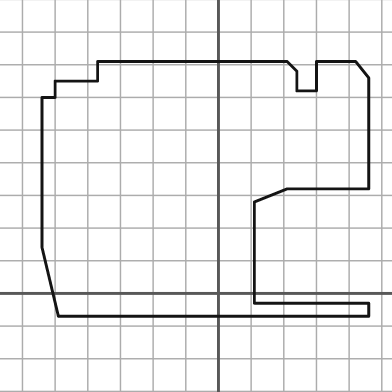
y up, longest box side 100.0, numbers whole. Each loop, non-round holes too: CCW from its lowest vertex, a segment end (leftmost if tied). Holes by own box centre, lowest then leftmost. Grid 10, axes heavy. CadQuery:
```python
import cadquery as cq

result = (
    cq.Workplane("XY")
    .moveTo(-49.0, -7.0)
    .lineTo(46.0, -7.0)
    .lineTo(46.0, -3.0)
    .lineTo(11.0, -3.0)
    .lineTo(11.0, 28.0)
    .lineTo(21.0, 32.0)
    .lineTo(46.0, 32.0)
    .lineTo(46.0, 66.0)
    .lineTo(42.0, 71.0)
    .lineTo(30.0, 71.0)
    .lineTo(30.0, 62.0)
    .lineTo(24.0, 62.0)
    .lineTo(24.0, 68.0)
    .lineTo(21.0, 71.0)
    .lineTo(-37.0, 71.0)
    .lineTo(-37.0, 65.0)
    .lineTo(-50.0, 65.0)
    .lineTo(-50.0, 60.0)
    .lineTo(-54.0, 60.0)
    .lineTo(-54.0, 14.0)
    .close()
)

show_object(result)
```